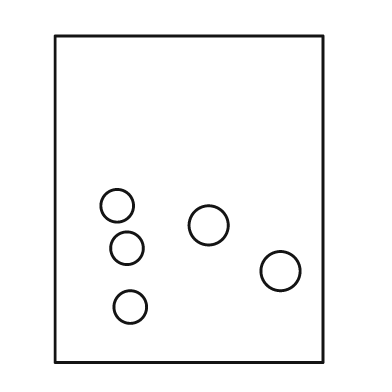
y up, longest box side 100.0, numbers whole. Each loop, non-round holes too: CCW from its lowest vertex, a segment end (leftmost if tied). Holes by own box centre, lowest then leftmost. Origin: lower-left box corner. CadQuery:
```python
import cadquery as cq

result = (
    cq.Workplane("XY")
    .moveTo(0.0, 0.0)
    .lineTo(82.0, 0.0)
    .lineTo(82.0, 100.0)
    .lineTo(0.0, 100.0)
    .close()
    .moveTo(23.0, 17.0)
    .circle(5.0)
    .moveTo(69.0, 28.0)
    .circle(6.0)
    .moveTo(22.0, 35.0)
    .circle(5.0)
    .moveTo(47.0, 42.0)
    .circle(6.0)
    .moveTo(19.0, 48.0)
    .circle(5.0)
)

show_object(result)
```